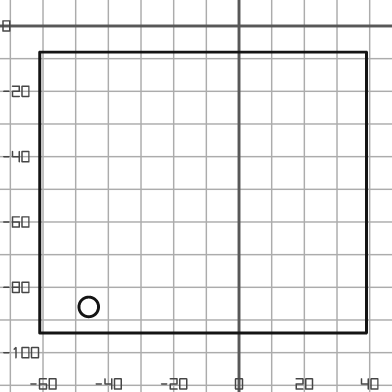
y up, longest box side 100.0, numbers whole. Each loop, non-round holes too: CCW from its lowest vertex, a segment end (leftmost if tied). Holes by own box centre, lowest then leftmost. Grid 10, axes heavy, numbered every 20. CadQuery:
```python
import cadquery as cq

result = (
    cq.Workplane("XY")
    .moveTo(-61.0, -94.0)
    .lineTo(39.0, -94.0)
    .lineTo(39.0, -8.0)
    .lineTo(-61.0, -8.0)
    .close()
    .moveTo(-46.0, -86.0)
    .circle(3.0)
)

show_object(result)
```